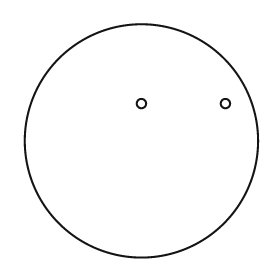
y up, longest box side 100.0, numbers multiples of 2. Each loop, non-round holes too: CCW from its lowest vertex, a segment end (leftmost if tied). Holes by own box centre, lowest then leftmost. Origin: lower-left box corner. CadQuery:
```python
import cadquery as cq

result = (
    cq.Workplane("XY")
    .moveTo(50.0, 50.0)
    .circle(50.0)
    .moveTo(50.0, 66.0)
    .circle(2.0)
    .moveTo(86.0, 66.0)
    .circle(2.0)
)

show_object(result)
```